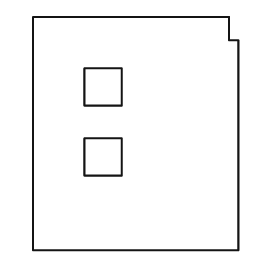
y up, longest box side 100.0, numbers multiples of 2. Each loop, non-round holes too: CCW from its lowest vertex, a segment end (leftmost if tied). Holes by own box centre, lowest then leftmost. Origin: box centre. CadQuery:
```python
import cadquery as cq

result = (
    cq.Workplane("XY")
    .moveTo(-44.0, -50.0)
    .lineTo(44.0, -50.0)
    .lineTo(44.0, 40.0)
    .lineTo(40.0, 40.0)
    .lineTo(40.0, 50.0)
    .lineTo(-44.0, 50.0)
    .close()
    .moveTo(-22.0, -18.0)
    .lineTo(-6.0, -18.0)
    .lineTo(-6.0, -2.0)
    .lineTo(-22.0, -2.0)
    .close()
    .moveTo(-22.0, 12.0)
    .lineTo(-6.0, 12.0)
    .lineTo(-6.0, 28.0)
    .lineTo(-22.0, 28.0)
    .close()
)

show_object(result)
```